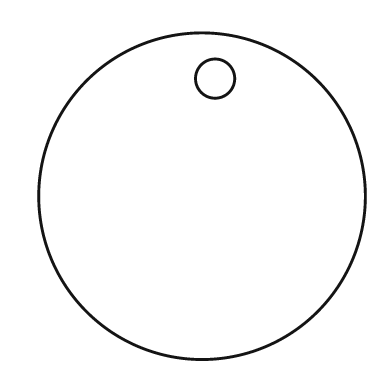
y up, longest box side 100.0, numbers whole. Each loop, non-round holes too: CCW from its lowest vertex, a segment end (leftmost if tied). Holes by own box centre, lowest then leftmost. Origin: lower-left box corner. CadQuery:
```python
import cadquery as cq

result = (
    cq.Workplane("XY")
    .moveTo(50.0, 50.0)
    .circle(50.0)
    .moveTo(54.0, 86.0)
    .circle(6.0)
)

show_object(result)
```